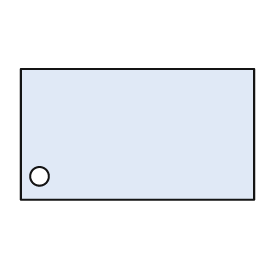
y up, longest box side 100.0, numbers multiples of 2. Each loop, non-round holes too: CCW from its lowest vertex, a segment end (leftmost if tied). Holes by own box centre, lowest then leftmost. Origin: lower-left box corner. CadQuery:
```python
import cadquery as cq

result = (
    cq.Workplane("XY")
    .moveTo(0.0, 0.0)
    .lineTo(100.0, 0.0)
    .lineTo(100.0, 56.0)
    .lineTo(0.0, 56.0)
    .close()
    .moveTo(8.0, 10.0)
    .circle(4.0)
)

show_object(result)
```